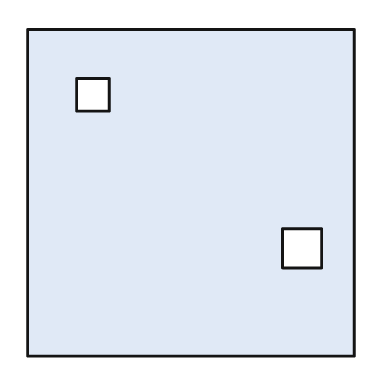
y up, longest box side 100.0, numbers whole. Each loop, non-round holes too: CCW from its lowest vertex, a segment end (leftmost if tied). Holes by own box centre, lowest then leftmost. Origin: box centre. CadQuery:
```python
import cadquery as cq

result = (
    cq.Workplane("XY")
    .moveTo(-50.0, -50.0)
    .lineTo(50.0, -50.0)
    .lineTo(50.0, 50.0)
    .lineTo(-50.0, 50.0)
    .close()
    .moveTo(28.0, -23.0)
    .lineTo(40.0, -23.0)
    .lineTo(40.0, -11.0)
    .lineTo(28.0, -11.0)
    .close()
    .moveTo(-35.0, 25.0)
    .lineTo(-25.0, 25.0)
    .lineTo(-25.0, 35.0)
    .lineTo(-35.0, 35.0)
    .close()
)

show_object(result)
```